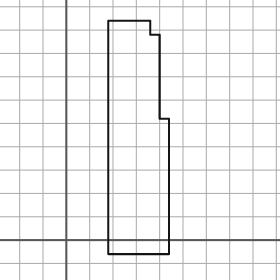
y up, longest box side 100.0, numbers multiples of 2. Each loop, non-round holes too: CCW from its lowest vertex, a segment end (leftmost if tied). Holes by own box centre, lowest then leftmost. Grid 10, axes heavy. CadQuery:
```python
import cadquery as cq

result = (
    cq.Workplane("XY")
    .moveTo(18.0, -6.0)
    .lineTo(44.0, -6.0)
    .lineTo(44.0, 52.0)
    .lineTo(40.0, 52.0)
    .lineTo(40.0, 88.0)
    .lineTo(36.0, 88.0)
    .lineTo(36.0, 94.0)
    .lineTo(18.0, 94.0)
    .close()
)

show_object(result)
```